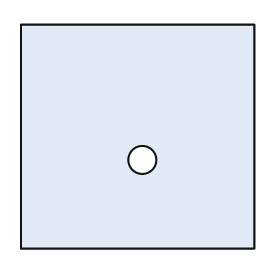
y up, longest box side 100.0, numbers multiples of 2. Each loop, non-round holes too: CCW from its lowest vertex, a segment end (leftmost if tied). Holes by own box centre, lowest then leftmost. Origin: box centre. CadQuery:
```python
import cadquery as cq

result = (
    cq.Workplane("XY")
    .moveTo(-50.0, -48.0)
    .lineTo(50.0, -48.0)
    .lineTo(50.0, 48.0)
    .lineTo(-50.0, 48.0)
    .close()
    .moveTo(2.0, -10.0)
    .circle(6.0)
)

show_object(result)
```